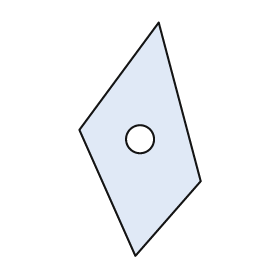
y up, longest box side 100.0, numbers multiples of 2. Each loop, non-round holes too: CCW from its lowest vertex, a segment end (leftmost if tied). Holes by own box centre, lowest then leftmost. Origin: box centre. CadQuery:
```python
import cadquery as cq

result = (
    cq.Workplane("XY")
    .moveTo(-2.0, -50.0)
    .lineTo(26.0, -18.0)
    .lineTo(8.0, 50.0)
    .lineTo(-26.0, 4.0)
    .close()
    .moveTo(0.0, 0.0)
    .circle(6.0)
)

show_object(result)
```